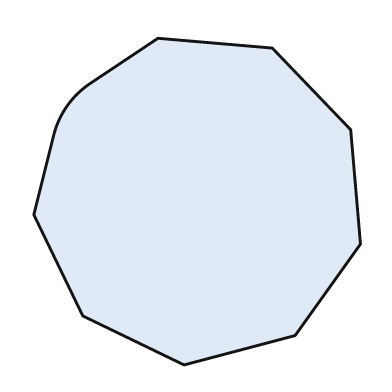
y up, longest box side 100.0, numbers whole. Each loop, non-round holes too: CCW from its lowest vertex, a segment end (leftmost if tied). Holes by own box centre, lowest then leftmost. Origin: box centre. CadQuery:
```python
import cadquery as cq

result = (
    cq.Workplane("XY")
    .moveTo(-4.0, -50.0)
    .lineTo(30.0, -41.0)
    .lineTo(50.0, -13.0)
    .lineTo(47.0, 22.0)
    .lineTo(23.0, 47.0)
    .lineTo(-12.0, 50.0)
    .lineTo(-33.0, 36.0)
    .threePointArc((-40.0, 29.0), (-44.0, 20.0))
    .lineTo(-50.0, -4.0)
    .lineTo(-35.0, -35.0)
    .close()
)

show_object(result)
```